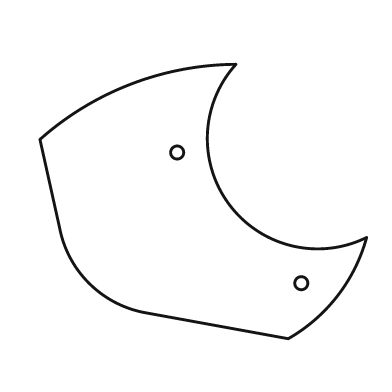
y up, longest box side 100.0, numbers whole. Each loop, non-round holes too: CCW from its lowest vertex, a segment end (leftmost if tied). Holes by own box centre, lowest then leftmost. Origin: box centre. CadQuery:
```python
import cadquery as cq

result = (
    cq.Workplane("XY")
    .moveTo(26.0, -42.0)
    .threePointArc((41.0, -29.0), (50.0, -11.0))
    .threePointArc((8.0, -1.0), (10.0, 42.0))
    .threePointArc((-22.0, 36.0), (-50.0, 19.0))
    .lineTo(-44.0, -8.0)
    .threePointArc((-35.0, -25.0), (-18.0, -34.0))
    .close()
    .moveTo(30.0, -25.0)
    .circle(2.0)
    .moveTo(-8.0, 15.0)
    .circle(2.0)
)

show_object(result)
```